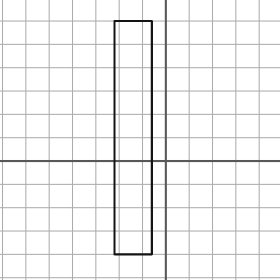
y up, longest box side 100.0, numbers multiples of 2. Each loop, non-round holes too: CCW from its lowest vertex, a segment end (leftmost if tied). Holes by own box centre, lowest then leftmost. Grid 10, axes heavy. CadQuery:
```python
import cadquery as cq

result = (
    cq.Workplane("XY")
    .moveTo(-22.0, -40.0)
    .lineTo(-6.0, -40.0)
    .lineTo(-6.0, 60.0)
    .lineTo(-22.0, 60.0)
    .close()
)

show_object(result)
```